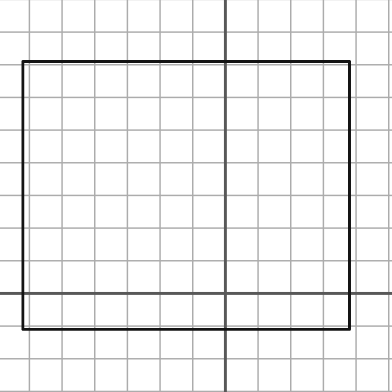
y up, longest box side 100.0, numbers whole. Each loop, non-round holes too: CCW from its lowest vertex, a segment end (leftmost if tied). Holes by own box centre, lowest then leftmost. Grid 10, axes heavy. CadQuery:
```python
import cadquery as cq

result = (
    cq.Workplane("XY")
    .moveTo(-62.0, -11.0)
    .lineTo(38.0, -11.0)
    .lineTo(38.0, 71.0)
    .lineTo(-62.0, 71.0)
    .close()
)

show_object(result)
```